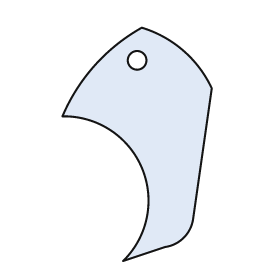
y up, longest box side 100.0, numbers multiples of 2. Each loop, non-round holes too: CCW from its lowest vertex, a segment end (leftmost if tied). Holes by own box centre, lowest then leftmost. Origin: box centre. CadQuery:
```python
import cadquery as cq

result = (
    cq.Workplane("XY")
    .moveTo(-6.0, -50.0)
    .lineTo(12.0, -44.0)
    .threePointArc((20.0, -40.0), (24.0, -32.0))
    .lineTo(32.0, 24.0)
    .threePointArc((20.0, 40.0), (2.0, 50.0))
    .threePointArc((-18.0, 34.0), (-32.0, 12.0))
    .threePointArc((2.0, -10.0), (-6.0, -50.0))
    .close()
    .moveTo(0.0, 36.0)
    .circle(4.0)
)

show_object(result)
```